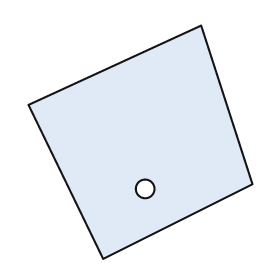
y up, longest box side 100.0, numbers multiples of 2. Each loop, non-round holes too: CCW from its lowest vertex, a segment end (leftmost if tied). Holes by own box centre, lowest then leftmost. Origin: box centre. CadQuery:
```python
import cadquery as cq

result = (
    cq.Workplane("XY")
    .moveTo(-16.0, -50.0)
    .lineTo(48.0, -18.0)
    .lineTo(26.0, 50.0)
    .lineTo(-48.0, 16.0)
    .close()
    .moveTo(2.0, -20.0)
    .circle(4.0)
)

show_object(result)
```